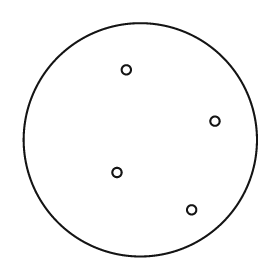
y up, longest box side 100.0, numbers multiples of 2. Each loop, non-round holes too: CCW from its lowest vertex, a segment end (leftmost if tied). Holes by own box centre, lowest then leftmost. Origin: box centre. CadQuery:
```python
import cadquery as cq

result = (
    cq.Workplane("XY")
    .moveTo(0.0, 0.0)
    .circle(50.0)
    .moveTo(22.0, -30.0)
    .circle(2.0)
    .moveTo(-10.0, -14.0)
    .circle(2.0)
    .moveTo(32.0, 8.0)
    .circle(2.0)
    .moveTo(-6.0, 30.0)
    .circle(2.0)
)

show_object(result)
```